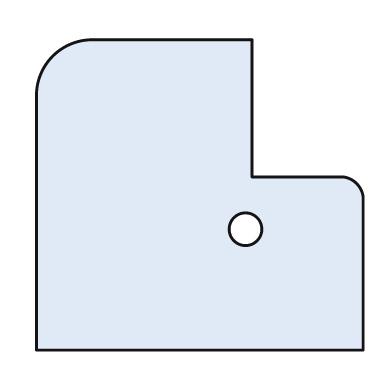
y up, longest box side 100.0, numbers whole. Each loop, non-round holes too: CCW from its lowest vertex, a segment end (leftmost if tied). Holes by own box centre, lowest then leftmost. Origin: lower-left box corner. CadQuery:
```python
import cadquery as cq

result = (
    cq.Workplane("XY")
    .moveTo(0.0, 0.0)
    .lineTo(100.0, 0.0)
    .lineTo(100.0, 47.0)
    .threePointArc((98.0, 51.0), (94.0, 53.0))
    .lineTo(66.0, 53.0)
    .lineTo(66.0, 95.0)
    .lineTo(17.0, 95.0)
    .threePointArc((5.0, 90.0), (0.0, 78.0))
    .close()
    .moveTo(64.0, 37.0)
    .circle(5.0)
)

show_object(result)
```